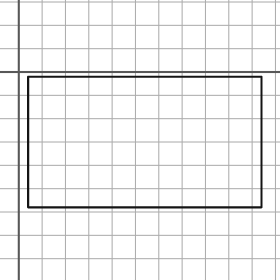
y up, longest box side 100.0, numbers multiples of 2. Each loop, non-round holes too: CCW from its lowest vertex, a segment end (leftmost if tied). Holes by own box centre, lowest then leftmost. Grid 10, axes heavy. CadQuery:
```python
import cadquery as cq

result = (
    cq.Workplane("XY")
    .moveTo(4.0, -58.0)
    .lineTo(104.0, -58.0)
    .lineTo(104.0, -2.0)
    .lineTo(4.0, -2.0)
    .close()
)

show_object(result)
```